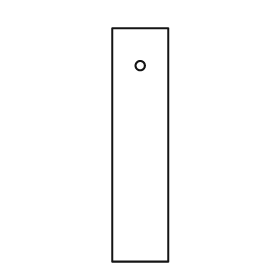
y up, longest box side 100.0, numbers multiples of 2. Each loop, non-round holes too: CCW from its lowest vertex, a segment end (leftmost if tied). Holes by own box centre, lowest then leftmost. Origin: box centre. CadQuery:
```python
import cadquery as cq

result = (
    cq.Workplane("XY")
    .moveTo(-12.0, -50.0)
    .lineTo(12.0, -50.0)
    .lineTo(12.0, 50.0)
    .lineTo(-12.0, 50.0)
    .close()
    .moveTo(0.0, 34.0)
    .circle(2.0)
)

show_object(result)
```